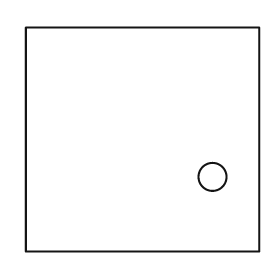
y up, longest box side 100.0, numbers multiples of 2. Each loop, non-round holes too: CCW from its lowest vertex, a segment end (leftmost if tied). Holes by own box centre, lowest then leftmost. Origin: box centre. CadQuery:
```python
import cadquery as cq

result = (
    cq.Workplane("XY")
    .moveTo(-50.0, -48.0)
    .lineTo(50.0, -48.0)
    .lineTo(50.0, 48.0)
    .lineTo(-50.0, 48.0)
    .close()
    .moveTo(30.0, -16.0)
    .circle(6.0)
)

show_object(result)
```